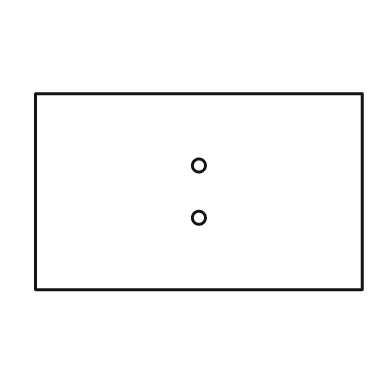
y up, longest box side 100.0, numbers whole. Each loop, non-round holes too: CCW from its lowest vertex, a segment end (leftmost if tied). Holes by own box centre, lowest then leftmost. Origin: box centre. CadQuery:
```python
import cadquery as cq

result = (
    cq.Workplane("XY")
    .moveTo(-50.0, -30.0)
    .lineTo(50.0, -30.0)
    .lineTo(50.0, 30.0)
    .lineTo(-50.0, 30.0)
    .close()
    .moveTo(0.0, -8.0)
    .circle(2.0)
    .moveTo(0.0, 8.0)
    .circle(2.0)
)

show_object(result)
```